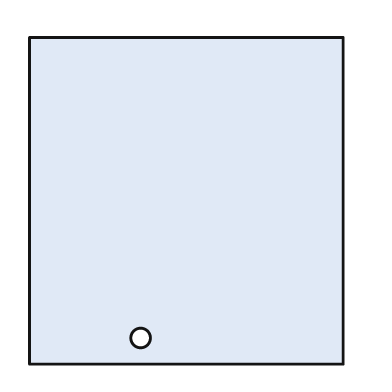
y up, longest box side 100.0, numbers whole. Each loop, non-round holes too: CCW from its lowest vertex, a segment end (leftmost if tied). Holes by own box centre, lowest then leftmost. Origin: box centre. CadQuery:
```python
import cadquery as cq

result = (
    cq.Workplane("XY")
    .moveTo(-48.0, -50.0)
    .lineTo(48.0, -50.0)
    .lineTo(48.0, 50.0)
    .lineTo(-48.0, 50.0)
    .close()
    .moveTo(-14.0, -42.0)
    .circle(3.0)
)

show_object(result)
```